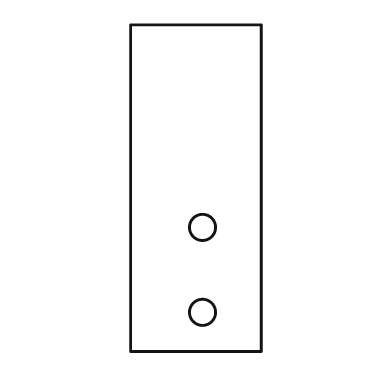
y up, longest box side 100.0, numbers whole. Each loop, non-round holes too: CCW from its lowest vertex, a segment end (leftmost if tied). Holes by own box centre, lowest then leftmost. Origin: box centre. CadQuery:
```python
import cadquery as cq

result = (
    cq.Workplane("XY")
    .moveTo(-20.0, -50.0)
    .lineTo(20.0, -50.0)
    .lineTo(20.0, 50.0)
    .lineTo(-20.0, 50.0)
    .close()
    .moveTo(2.0, -38.0)
    .circle(4.0)
    .moveTo(2.0, -12.0)
    .circle(4.0)
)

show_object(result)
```